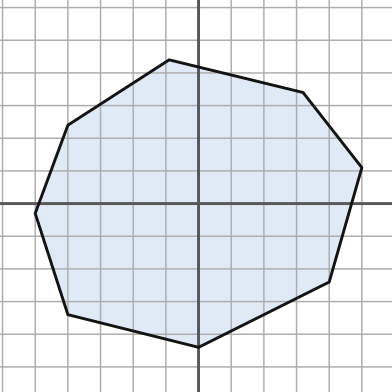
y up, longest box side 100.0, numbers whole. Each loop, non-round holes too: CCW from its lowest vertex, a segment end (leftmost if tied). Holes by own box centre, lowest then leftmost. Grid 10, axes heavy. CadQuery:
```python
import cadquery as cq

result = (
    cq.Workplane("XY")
    .moveTo(0.0, -44.0)
    .lineTo(40.0, -24.0)
    .lineTo(50.0, 11.0)
    .lineTo(32.0, 34.0)
    .lineTo(-9.0, 44.0)
    .lineTo(-40.0, 24.0)
    .lineTo(-50.0, -3.0)
    .lineTo(-40.0, -34.0)
    .close()
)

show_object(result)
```